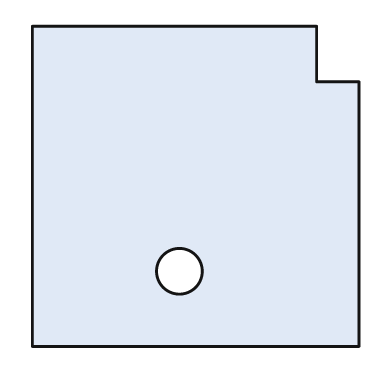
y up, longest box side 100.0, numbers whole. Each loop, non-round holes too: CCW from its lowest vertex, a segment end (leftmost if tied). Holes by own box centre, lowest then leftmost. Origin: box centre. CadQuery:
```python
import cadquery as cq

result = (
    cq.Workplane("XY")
    .moveTo(-50.0, -49.0)
    .lineTo(50.0, -49.0)
    .lineTo(50.0, 32.0)
    .lineTo(37.0, 32.0)
    .lineTo(37.0, 49.0)
    .lineTo(-50.0, 49.0)
    .close()
    .moveTo(-5.0, -26.0)
    .circle(7.0)
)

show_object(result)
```